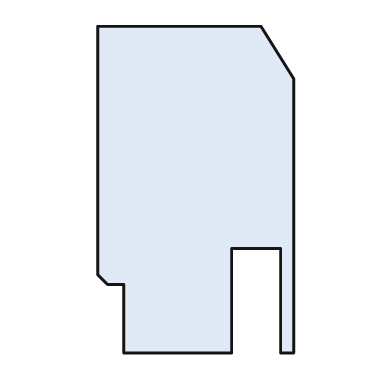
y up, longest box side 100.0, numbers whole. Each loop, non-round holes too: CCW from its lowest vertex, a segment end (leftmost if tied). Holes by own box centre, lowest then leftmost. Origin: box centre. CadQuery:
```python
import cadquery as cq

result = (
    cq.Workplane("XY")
    .moveTo(-22.0, -50.0)
    .lineTo(11.0, -50.0)
    .lineTo(11.0, -18.0)
    .lineTo(26.0, -18.0)
    .lineTo(26.0, -50.0)
    .lineTo(30.0, -50.0)
    .lineTo(30.0, 34.0)
    .lineTo(20.0, 50.0)
    .lineTo(-30.0, 50.0)
    .lineTo(-30.0, -26.0)
    .lineTo(-27.0, -29.0)
    .lineTo(-22.0, -29.0)
    .close()
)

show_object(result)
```